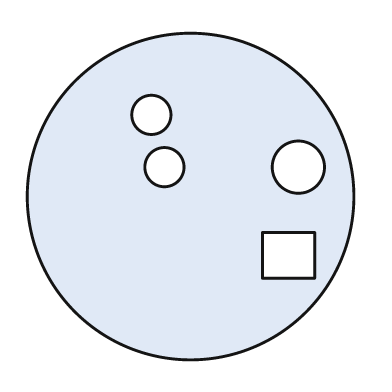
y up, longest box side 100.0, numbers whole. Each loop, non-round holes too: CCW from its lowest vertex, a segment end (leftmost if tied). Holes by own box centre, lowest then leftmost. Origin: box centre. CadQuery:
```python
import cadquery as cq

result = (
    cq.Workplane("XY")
    .moveTo(0.0, 0.0)
    .circle(50.0)
    .moveTo(22.0, -25.0)
    .lineTo(38.0, -25.0)
    .lineTo(38.0, -11.0)
    .lineTo(22.0, -11.0)
    .close()
    .moveTo(-8.0, 9.0)
    .circle(6.0)
    .moveTo(33.0, 9.0)
    .circle(8.0)
    .moveTo(-12.0, 25.0)
    .circle(6.0)
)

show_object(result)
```